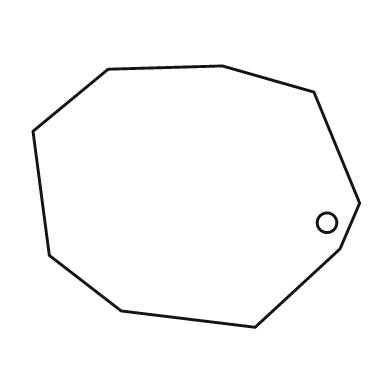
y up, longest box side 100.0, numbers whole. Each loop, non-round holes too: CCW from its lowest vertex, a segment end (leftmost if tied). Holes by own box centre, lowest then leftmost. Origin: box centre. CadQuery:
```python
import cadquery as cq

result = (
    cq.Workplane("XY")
    .moveTo(18.0, -40.0)
    .lineTo(44.0, -16.0)
    .lineTo(50.0, -2.0)
    .lineTo(36.0, 32.0)
    .lineTo(8.0, 40.0)
    .lineTo(-27.0, 39.0)
    .lineTo(-50.0, 20.0)
    .lineTo(-45.0, -18.0)
    .lineTo(-23.0, -35.0)
    .close()
    .moveTo(40.0, -8.0)
    .circle(3.0)
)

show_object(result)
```